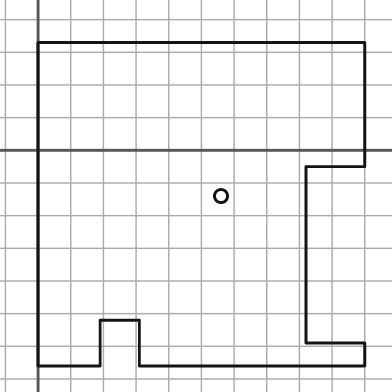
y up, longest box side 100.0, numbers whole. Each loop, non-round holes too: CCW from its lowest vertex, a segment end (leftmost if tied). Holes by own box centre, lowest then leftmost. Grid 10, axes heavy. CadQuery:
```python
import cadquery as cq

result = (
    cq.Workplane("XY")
    .moveTo(0.0, -66.0)
    .lineTo(19.0, -66.0)
    .lineTo(19.0, -52.0)
    .lineTo(31.0, -52.0)
    .lineTo(31.0, -66.0)
    .lineTo(100.0, -66.0)
    .lineTo(100.0, -59.0)
    .lineTo(82.0, -59.0)
    .lineTo(82.0, -5.0)
    .lineTo(100.0, -5.0)
    .lineTo(100.0, 33.0)
    .lineTo(0.0, 33.0)
    .close()
    .moveTo(56.0, -14.0)
    .circle(2.0)
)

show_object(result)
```